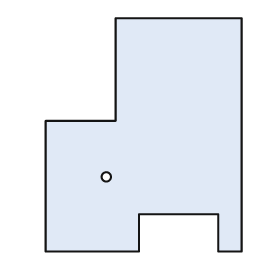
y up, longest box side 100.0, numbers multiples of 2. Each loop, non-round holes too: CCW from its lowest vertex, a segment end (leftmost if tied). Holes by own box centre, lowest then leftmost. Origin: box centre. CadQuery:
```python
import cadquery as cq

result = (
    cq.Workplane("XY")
    .moveTo(-42.0, -50.0)
    .lineTo(-2.0, -50.0)
    .lineTo(-2.0, -34.0)
    .lineTo(32.0, -34.0)
    .lineTo(32.0, -50.0)
    .lineTo(42.0, -50.0)
    .lineTo(42.0, 50.0)
    .lineTo(-12.0, 50.0)
    .lineTo(-12.0, 6.0)
    .lineTo(-42.0, 6.0)
    .close()
    .moveTo(-16.0, -18.0)
    .circle(2.0)
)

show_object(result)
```